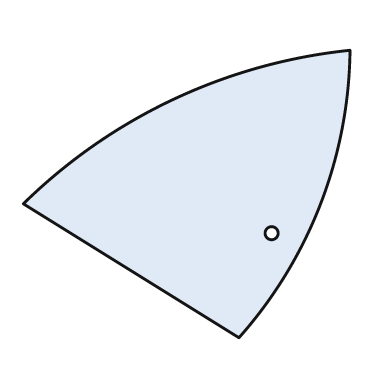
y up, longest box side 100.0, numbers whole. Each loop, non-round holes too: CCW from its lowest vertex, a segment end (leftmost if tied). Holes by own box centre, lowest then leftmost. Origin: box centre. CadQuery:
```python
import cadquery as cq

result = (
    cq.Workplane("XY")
    .moveTo(16.0, -44.0)
    .threePointArc((41.0, -3.0), (50.0, 44.0))
    .threePointArc((-4.0, 29.0), (-50.0, -3.0))
    .close()
    .moveTo(26.0, -12.0)
    .circle(2.0)
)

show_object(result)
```